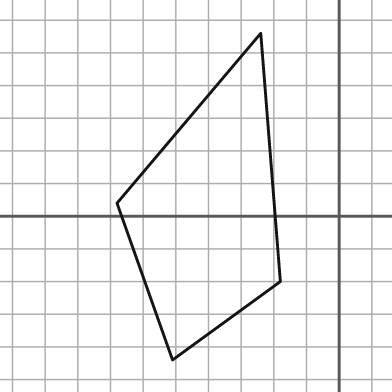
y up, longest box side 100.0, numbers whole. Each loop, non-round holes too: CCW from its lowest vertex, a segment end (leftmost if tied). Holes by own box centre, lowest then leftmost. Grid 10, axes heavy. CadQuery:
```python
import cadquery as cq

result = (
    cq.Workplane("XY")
    .moveTo(-51.0, -44.0)
    .lineTo(-18.0, -20.0)
    .lineTo(-24.0, 56.0)
    .lineTo(-68.0, 4.0)
    .close()
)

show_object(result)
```